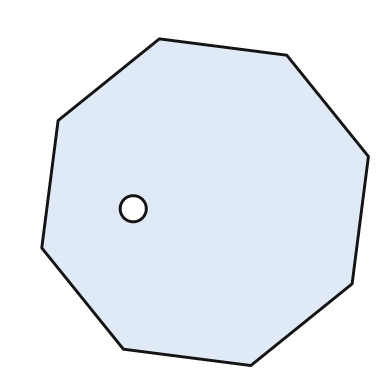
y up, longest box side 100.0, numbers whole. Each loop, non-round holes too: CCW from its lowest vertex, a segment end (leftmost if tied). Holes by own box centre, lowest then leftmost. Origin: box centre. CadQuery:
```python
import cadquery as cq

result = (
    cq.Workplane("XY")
    .moveTo(14.0, -50.0)
    .lineTo(45.0, -25.0)
    .lineTo(50.0, 14.0)
    .lineTo(25.0, 45.0)
    .lineTo(-14.0, 50.0)
    .lineTo(-45.0, 25.0)
    .lineTo(-50.0, -14.0)
    .lineTo(-25.0, -45.0)
    .close()
    .moveTo(-22.0, -2.0)
    .circle(4.0)
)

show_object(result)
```